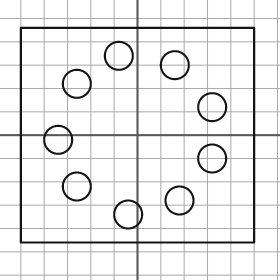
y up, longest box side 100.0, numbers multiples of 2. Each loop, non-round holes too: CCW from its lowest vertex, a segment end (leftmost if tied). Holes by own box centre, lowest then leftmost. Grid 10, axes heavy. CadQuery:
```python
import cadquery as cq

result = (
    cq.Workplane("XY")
    .moveTo(-50.0, -46.0)
    .lineTo(50.0, -46.0)
    .lineTo(50.0, 46.0)
    .lineTo(-50.0, 46.0)
    .close()
    .moveTo(-4.0, -34.0)
    .circle(6.0)
    .moveTo(18.0, -28.0)
    .circle(6.0)
    .moveTo(-26.0, -22.0)
    .circle(6.0)
    .moveTo(32.0, -10.0)
    .circle(6.0)
    .moveTo(-34.0, -2.0)
    .circle(6.0)
    .moveTo(32.0, 12.0)
    .circle(6.0)
    .moveTo(-26.0, 22.0)
    .circle(6.0)
    .moveTo(16.0, 30.0)
    .circle(6.0)
    .moveTo(-8.0, 34.0)
    .circle(6.0)
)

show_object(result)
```